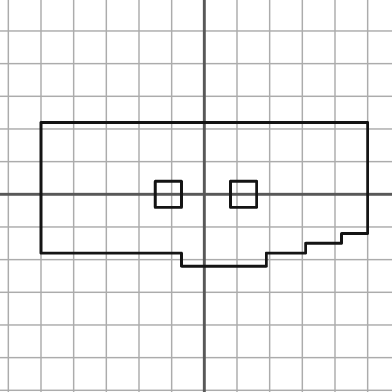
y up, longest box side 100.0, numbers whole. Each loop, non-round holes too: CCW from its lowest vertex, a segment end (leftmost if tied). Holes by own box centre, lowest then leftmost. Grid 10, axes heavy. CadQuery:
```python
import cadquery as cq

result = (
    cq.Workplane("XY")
    .moveTo(-7.0, -22.0)
    .lineTo(19.0, -22.0)
    .lineTo(19.0, -18.0)
    .lineTo(31.0, -18.0)
    .lineTo(31.0, -15.0)
    .lineTo(42.0, -15.0)
    .lineTo(42.0, -12.0)
    .lineTo(50.0, -12.0)
    .lineTo(50.0, 22.0)
    .lineTo(-50.0, 22.0)
    .lineTo(-50.0, -18.0)
    .lineTo(-7.0, -18.0)
    .close()
    .moveTo(-15.0, -4.0)
    .lineTo(-7.0, -4.0)
    .lineTo(-7.0, 4.0)
    .lineTo(-15.0, 4.0)
    .close()
    .moveTo(8.0, -4.0)
    .lineTo(16.0, -4.0)
    .lineTo(16.0, 4.0)
    .lineTo(8.0, 4.0)
    .close()
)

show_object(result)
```